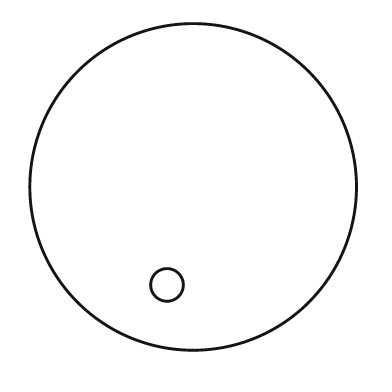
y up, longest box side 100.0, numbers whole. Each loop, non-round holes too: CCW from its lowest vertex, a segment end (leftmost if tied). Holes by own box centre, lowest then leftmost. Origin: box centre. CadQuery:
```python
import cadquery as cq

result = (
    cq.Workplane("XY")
    .moveTo(0.0, 0.0)
    .circle(50.0)
    .moveTo(-8.0, -30.0)
    .circle(5.0)
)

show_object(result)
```